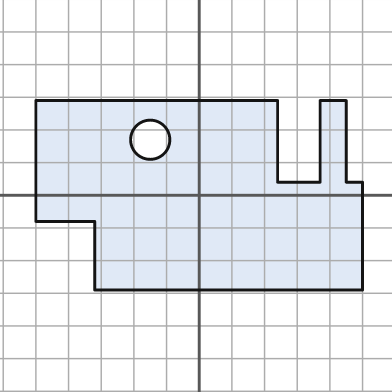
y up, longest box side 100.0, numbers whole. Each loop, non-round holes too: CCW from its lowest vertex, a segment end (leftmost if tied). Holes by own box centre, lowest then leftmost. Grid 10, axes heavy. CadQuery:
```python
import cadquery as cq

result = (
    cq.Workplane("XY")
    .moveTo(-32.0, -29.0)
    .lineTo(50.0, -29.0)
    .lineTo(50.0, 4.0)
    .lineTo(45.0, 4.0)
    .lineTo(45.0, 29.0)
    .lineTo(37.0, 29.0)
    .lineTo(37.0, 4.0)
    .lineTo(24.0, 4.0)
    .lineTo(24.0, 29.0)
    .lineTo(-50.0, 29.0)
    .lineTo(-50.0, -8.0)
    .lineTo(-32.0, -8.0)
    .close()
    .moveTo(-15.0, 17.0)
    .circle(6.0)
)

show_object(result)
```